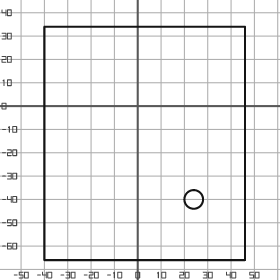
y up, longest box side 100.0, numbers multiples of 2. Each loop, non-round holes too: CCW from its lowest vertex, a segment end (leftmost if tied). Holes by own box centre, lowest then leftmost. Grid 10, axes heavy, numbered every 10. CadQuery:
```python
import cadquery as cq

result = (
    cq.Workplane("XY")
    .moveTo(-40.0, -66.0)
    .lineTo(46.0, -66.0)
    .lineTo(46.0, 34.0)
    .lineTo(-40.0, 34.0)
    .close()
    .moveTo(24.0, -40.0)
    .circle(4.0)
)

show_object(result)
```